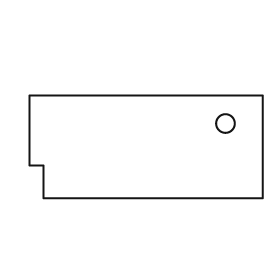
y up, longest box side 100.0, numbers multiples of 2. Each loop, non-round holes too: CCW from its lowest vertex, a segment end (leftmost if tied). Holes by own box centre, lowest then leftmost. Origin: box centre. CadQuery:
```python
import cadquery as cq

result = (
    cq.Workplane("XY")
    .moveTo(-44.0, -22.0)
    .lineTo(50.0, -22.0)
    .lineTo(50.0, 22.0)
    .lineTo(-50.0, 22.0)
    .lineTo(-50.0, -8.0)
    .lineTo(-44.0, -8.0)
    .close()
    .moveTo(34.0, 10.0)
    .circle(4.0)
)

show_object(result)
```